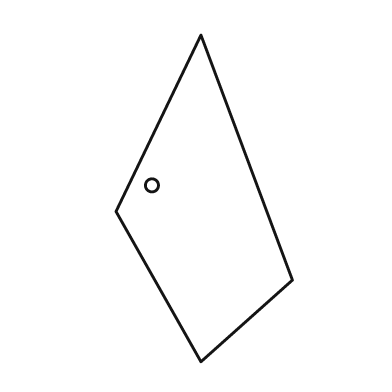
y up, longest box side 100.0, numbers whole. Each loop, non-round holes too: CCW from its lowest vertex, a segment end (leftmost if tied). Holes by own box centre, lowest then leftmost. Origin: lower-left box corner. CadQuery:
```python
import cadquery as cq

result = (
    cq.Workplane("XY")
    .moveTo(26.0, 0.0)
    .lineTo(54.0, 25.0)
    .lineTo(26.0, 100.0)
    .lineTo(0.0, 46.0)
    .close()
    .moveTo(11.0, 54.0)
    .circle(2.0)
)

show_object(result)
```